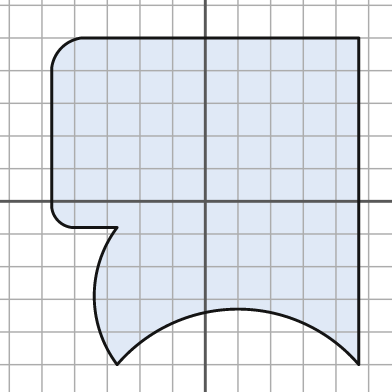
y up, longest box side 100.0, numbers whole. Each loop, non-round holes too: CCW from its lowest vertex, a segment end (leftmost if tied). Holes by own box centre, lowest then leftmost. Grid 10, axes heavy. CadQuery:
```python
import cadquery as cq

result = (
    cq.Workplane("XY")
    .moveTo(-27.0, -50.0)
    .threePointArc((10.0, -33.0), (47.0, -50.0))
    .lineTo(47.0, 50.0)
    .lineTo(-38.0, 50.0)
    .threePointArc((-44.0, 47.0), (-47.0, 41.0))
    .lineTo(-47.0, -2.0)
    .threePointArc((-45.0, -6.0), (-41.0, -8.0))
    .lineTo(-27.0, -8.0)
    .threePointArc((-34.0, -29.0), (-27.0, -50.0))
    .close()
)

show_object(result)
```